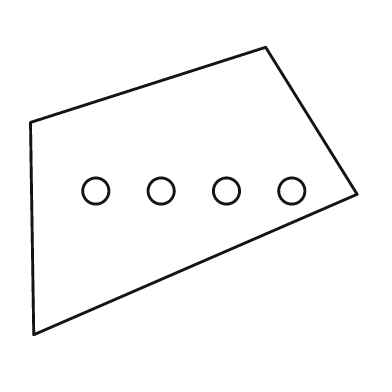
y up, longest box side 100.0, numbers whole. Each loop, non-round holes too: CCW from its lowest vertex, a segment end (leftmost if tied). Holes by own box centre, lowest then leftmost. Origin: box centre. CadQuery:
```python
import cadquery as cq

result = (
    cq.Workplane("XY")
    .moveTo(-49.0, -44.0)
    .lineTo(50.0, -1.0)
    .lineTo(22.0, 44.0)
    .lineTo(-50.0, 21.0)
    .close()
    .moveTo(-30.0, 0.0)
    .circle(4.0)
    .moveTo(-10.0, 0.0)
    .circle(4.0)
    .moveTo(10.0, 0.0)
    .circle(4.0)
    .moveTo(30.0, 0.0)
    .circle(4.0)
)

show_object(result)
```